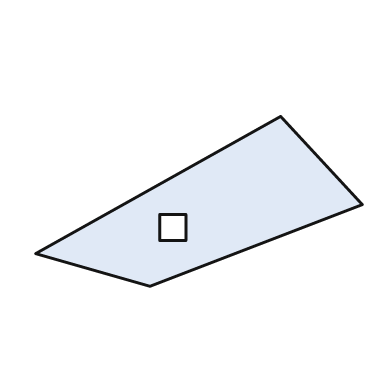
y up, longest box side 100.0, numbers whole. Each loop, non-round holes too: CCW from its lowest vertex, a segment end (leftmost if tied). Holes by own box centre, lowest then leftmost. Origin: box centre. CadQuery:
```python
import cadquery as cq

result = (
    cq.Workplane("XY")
    .moveTo(-15.0, -26.0)
    .lineTo(50.0, -1.0)
    .lineTo(25.0, 26.0)
    .lineTo(-50.0, -16.0)
    .close()
    .moveTo(-12.0, -12.0)
    .lineTo(-4.0, -12.0)
    .lineTo(-4.0, -4.0)
    .lineTo(-12.0, -4.0)
    .close()
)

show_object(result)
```